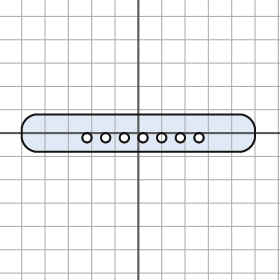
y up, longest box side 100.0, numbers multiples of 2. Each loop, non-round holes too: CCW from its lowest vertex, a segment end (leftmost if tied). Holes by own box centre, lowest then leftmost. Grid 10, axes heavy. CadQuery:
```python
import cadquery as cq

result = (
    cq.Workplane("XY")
    .moveTo(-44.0, -8.0)
    .lineTo(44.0, -8.0)
    .threePointArc((48.0, -6.0), (50.0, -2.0))
    .lineTo(50.0, 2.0)
    .threePointArc((48.0, 6.0), (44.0, 8.0))
    .lineTo(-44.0, 8.0)
    .threePointArc((-48.0, 6.0), (-50.0, 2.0))
    .lineTo(-50.0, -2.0)
    .threePointArc((-48.0, -6.0), (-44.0, -8.0))
    .close()
    .moveTo(-22.0, -2.0)
    .circle(2.0)
    .moveTo(-14.0, -2.0)
    .circle(2.0)
    .moveTo(-6.0, -2.0)
    .circle(2.0)
    .moveTo(2.0, -2.0)
    .circle(2.0)
    .moveTo(10.0, -2.0)
    .circle(2.0)
    .moveTo(18.0, -2.0)
    .circle(2.0)
    .moveTo(26.0, -2.0)
    .circle(2.0)
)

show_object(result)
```